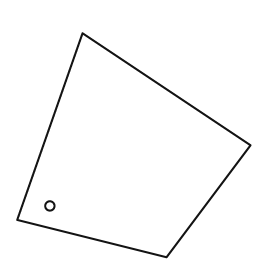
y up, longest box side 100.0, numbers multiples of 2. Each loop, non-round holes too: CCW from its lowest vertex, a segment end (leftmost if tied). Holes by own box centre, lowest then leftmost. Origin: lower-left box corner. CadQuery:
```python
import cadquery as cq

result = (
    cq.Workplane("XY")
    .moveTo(64.0, 0.0)
    .lineTo(100.0, 48.0)
    .lineTo(28.0, 96.0)
    .lineTo(0.0, 16.0)
    .close()
    .moveTo(14.0, 22.0)
    .circle(2.0)
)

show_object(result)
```